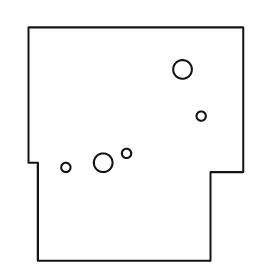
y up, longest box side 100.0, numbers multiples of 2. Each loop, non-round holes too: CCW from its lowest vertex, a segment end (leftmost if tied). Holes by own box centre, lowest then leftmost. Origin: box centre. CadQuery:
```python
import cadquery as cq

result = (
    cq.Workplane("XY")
    .moveTo(-42.0, -50.0)
    .lineTo(32.0, -50.0)
    .lineTo(32.0, -12.0)
    .lineTo(46.0, -12.0)
    .lineTo(46.0, 50.0)
    .lineTo(-46.0, 50.0)
    .lineTo(-46.0, -8.0)
    .lineTo(-42.0, -8.0)
    .close()
    .moveTo(-30.0, -10.0)
    .circle(2.0)
    .moveTo(-14.0, -8.0)
    .circle(4.0)
    .moveTo(-4.0, -4.0)
    .circle(2.0)
    .moveTo(28.0, 12.0)
    .circle(2.0)
    .moveTo(20.0, 32.0)
    .circle(4.0)
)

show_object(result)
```